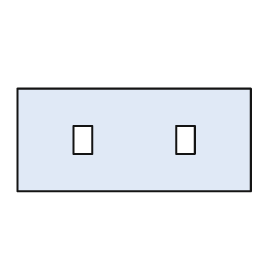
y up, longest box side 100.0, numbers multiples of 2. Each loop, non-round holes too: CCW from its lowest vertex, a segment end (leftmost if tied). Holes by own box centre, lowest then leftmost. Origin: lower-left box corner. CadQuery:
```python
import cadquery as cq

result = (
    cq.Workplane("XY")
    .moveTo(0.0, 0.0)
    .lineTo(100.0, 0.0)
    .lineTo(100.0, 44.0)
    .lineTo(0.0, 44.0)
    .close()
    .moveTo(24.0, 16.0)
    .lineTo(32.0, 16.0)
    .lineTo(32.0, 28.0)
    .lineTo(24.0, 28.0)
    .close()
    .moveTo(68.0, 16.0)
    .lineTo(76.0, 16.0)
    .lineTo(76.0, 28.0)
    .lineTo(68.0, 28.0)
    .close()
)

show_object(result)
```